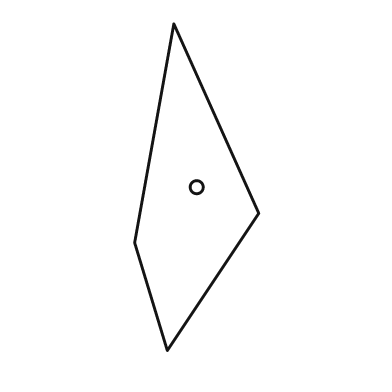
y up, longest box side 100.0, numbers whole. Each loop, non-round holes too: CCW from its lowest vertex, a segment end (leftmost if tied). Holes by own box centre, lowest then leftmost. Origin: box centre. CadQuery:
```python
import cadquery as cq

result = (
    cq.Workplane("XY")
    .moveTo(-9.0, -50.0)
    .lineTo(19.0, -8.0)
    .lineTo(-7.0, 50.0)
    .lineTo(-19.0, -17.0)
    .close()
    .moveTo(0.0, 0.0)
    .circle(2.0)
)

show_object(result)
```